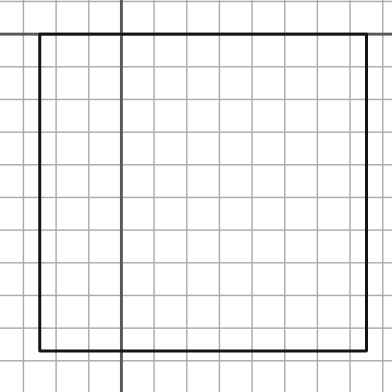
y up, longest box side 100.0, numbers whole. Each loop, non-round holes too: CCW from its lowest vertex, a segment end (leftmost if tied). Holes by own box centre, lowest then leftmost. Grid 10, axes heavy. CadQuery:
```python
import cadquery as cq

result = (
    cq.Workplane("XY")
    .moveTo(-25.0, -97.0)
    .lineTo(75.0, -97.0)
    .lineTo(75.0, 0.0)
    .lineTo(-25.0, 0.0)
    .close()
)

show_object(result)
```